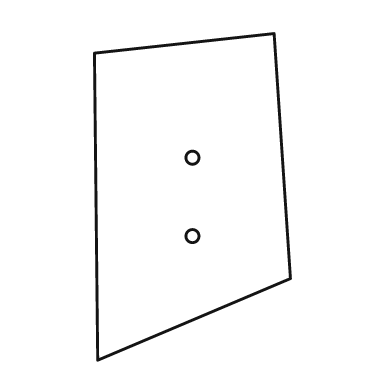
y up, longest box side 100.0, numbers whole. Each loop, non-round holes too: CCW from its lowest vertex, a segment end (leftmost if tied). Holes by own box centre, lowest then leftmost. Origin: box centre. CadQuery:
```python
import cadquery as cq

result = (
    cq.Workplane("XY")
    .moveTo(-29.0, -50.0)
    .lineTo(30.0, -25.0)
    .lineTo(25.0, 50.0)
    .lineTo(-30.0, 44.0)
    .close()
    .moveTo(0.0, -12.0)
    .circle(2.0)
    .moveTo(0.0, 12.0)
    .circle(2.0)
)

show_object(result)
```